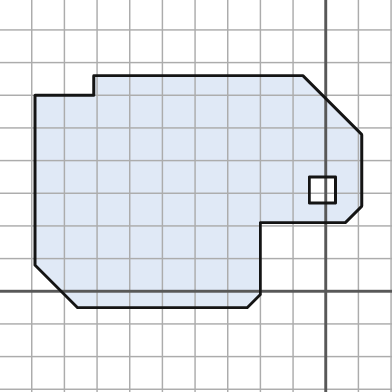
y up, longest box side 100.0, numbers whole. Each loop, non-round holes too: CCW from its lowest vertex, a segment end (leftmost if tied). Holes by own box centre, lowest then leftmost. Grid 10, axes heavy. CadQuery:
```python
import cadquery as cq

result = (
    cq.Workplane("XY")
    .moveTo(-76.0, -5.0)
    .lineTo(-24.0, -5.0)
    .lineTo(-20.0, -1.0)
    .lineTo(-20.0, 21.0)
    .lineTo(6.0, 21.0)
    .lineTo(11.0, 26.0)
    .lineTo(11.0, 48.0)
    .lineTo(-7.0, 66.0)
    .lineTo(-71.0, 66.0)
    .lineTo(-71.0, 60.0)
    .lineTo(-89.0, 60.0)
    .lineTo(-89.0, 8.0)
    .close()
    .moveTo(-5.0, 27.0)
    .lineTo(3.0, 27.0)
    .lineTo(3.0, 35.0)
    .lineTo(-5.0, 35.0)
    .close()
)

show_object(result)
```